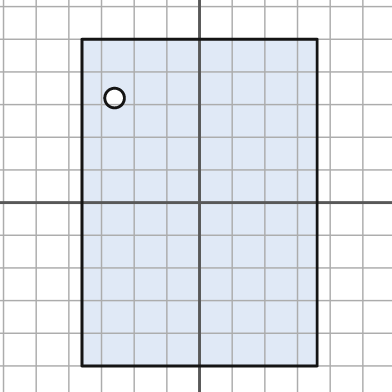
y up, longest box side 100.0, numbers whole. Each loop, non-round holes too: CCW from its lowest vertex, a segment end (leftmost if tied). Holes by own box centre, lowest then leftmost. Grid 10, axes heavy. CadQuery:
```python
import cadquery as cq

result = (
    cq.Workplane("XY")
    .moveTo(-36.0, -50.0)
    .lineTo(36.0, -50.0)
    .lineTo(36.0, 50.0)
    .lineTo(-36.0, 50.0)
    .close()
    .moveTo(-26.0, 32.0)
    .circle(3.0)
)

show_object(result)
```